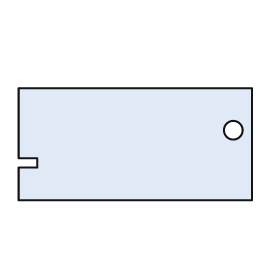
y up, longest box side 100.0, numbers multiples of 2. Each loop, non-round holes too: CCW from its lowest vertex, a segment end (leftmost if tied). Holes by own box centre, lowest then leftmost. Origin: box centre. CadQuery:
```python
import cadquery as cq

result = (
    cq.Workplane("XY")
    .moveTo(-50.0, -24.0)
    .lineTo(50.0, -24.0)
    .lineTo(50.0, 24.0)
    .lineTo(-50.0, 24.0)
    .lineTo(-50.0, -6.0)
    .lineTo(-42.0, -6.0)
    .lineTo(-42.0, -10.0)
    .lineTo(-50.0, -10.0)
    .close()
    .moveTo(42.0, 6.0)
    .circle(4.0)
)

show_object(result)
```